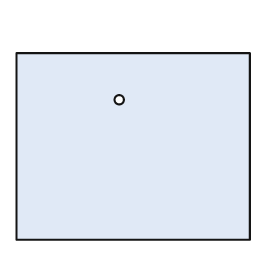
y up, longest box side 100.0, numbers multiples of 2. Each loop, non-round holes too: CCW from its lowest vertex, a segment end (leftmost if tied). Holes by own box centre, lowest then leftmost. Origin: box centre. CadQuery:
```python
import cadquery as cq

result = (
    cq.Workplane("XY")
    .moveTo(-50.0, -40.0)
    .lineTo(50.0, -40.0)
    .lineTo(50.0, 40.0)
    .lineTo(-50.0, 40.0)
    .close()
    .moveTo(-6.0, 20.0)
    .circle(2.0)
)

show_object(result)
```